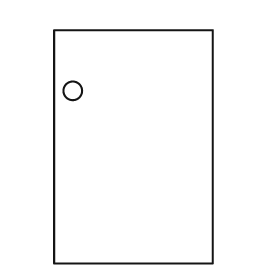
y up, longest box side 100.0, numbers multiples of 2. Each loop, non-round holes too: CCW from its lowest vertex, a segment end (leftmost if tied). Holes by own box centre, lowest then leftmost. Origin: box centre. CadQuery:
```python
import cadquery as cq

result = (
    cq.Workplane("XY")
    .moveTo(-34.0, -50.0)
    .lineTo(34.0, -50.0)
    .lineTo(34.0, 50.0)
    .lineTo(-34.0, 50.0)
    .close()
    .moveTo(-26.0, 24.0)
    .circle(4.0)
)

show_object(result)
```